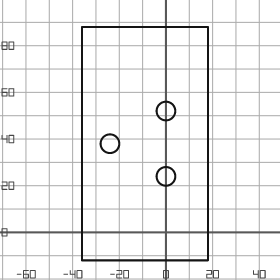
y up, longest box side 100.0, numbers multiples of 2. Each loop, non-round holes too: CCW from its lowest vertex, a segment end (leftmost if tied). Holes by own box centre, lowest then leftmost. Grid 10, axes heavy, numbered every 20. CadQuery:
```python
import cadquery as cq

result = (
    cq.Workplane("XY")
    .moveTo(-36.0, -12.0)
    .lineTo(18.0, -12.0)
    .lineTo(18.0, 88.0)
    .lineTo(-36.0, 88.0)
    .close()
    .moveTo(0.0, 24.0)
    .circle(4.0)
    .moveTo(-24.0, 38.0)
    .circle(4.0)
    .moveTo(0.0, 52.0)
    .circle(4.0)
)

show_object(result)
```